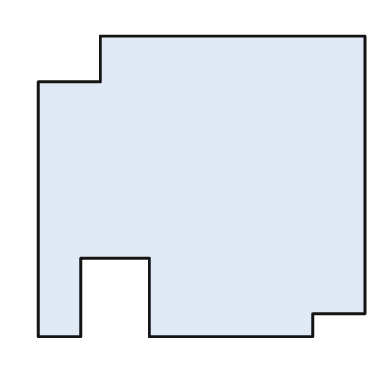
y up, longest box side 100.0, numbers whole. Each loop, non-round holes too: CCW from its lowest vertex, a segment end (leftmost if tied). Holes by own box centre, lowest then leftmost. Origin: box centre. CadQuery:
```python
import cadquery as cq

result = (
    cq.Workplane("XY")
    .moveTo(-50.0, -46.0)
    .lineTo(-37.0, -46.0)
    .lineTo(-37.0, -22.0)
    .lineTo(-16.0, -22.0)
    .lineTo(-16.0, -46.0)
    .lineTo(34.0, -46.0)
    .lineTo(34.0, -39.0)
    .lineTo(50.0, -39.0)
    .lineTo(50.0, 46.0)
    .lineTo(-31.0, 46.0)
    .lineTo(-31.0, 32.0)
    .lineTo(-50.0, 32.0)
    .close()
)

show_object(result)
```